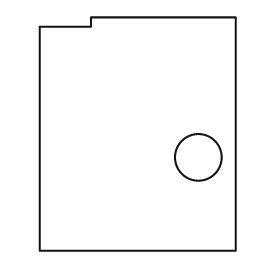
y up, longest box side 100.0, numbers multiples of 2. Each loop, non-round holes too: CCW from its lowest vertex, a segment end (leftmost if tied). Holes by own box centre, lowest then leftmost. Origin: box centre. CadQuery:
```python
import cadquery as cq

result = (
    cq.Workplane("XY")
    .moveTo(-42.0, -50.0)
    .lineTo(42.0, -50.0)
    .lineTo(42.0, 50.0)
    .lineTo(-20.0, 50.0)
    .lineTo(-20.0, 46.0)
    .lineTo(-42.0, 46.0)
    .close()
    .moveTo(26.0, -10.0)
    .circle(10.0)
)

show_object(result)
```